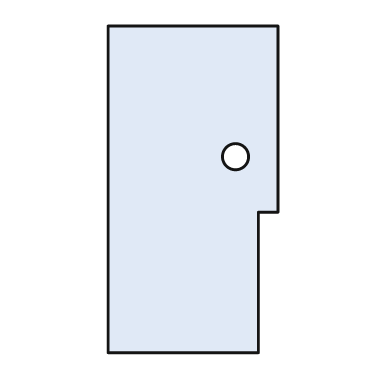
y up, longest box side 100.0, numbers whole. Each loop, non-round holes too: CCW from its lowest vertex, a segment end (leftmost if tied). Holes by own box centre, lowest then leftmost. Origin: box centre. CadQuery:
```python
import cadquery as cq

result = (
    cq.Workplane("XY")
    .moveTo(-26.0, -50.0)
    .lineTo(20.0, -50.0)
    .lineTo(20.0, -7.0)
    .lineTo(26.0, -7.0)
    .lineTo(26.0, 50.0)
    .lineTo(-26.0, 50.0)
    .close()
    .moveTo(13.0, 10.0)
    .circle(4.0)
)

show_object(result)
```